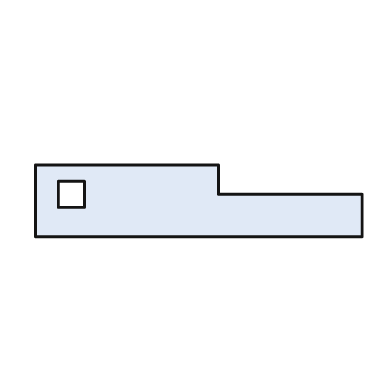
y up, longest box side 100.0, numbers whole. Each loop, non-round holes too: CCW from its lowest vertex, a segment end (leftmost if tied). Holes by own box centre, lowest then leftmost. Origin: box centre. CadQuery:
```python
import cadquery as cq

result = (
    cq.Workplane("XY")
    .moveTo(-50.0, -11.0)
    .lineTo(50.0, -11.0)
    .lineTo(50.0, 2.0)
    .lineTo(6.0, 2.0)
    .lineTo(6.0, 11.0)
    .lineTo(-50.0, 11.0)
    .close()
    .moveTo(-43.0, -2.0)
    .lineTo(-35.0, -2.0)
    .lineTo(-35.0, 6.0)
    .lineTo(-43.0, 6.0)
    .close()
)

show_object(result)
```